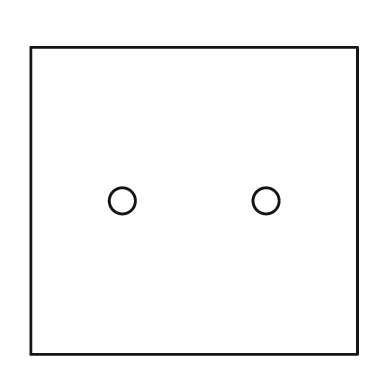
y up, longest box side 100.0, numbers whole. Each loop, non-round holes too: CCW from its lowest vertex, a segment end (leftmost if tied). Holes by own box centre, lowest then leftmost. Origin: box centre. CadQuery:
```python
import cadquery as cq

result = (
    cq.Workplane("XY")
    .moveTo(-50.0, -47.0)
    .lineTo(50.0, -47.0)
    .lineTo(50.0, 47.0)
    .lineTo(-50.0, 47.0)
    .close()
    .moveTo(-22.0, 0.0)
    .circle(4.0)
    .moveTo(22.0, 0.0)
    .circle(4.0)
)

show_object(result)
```